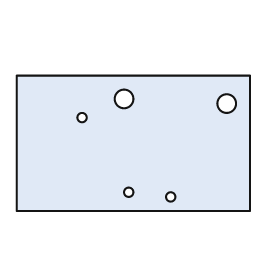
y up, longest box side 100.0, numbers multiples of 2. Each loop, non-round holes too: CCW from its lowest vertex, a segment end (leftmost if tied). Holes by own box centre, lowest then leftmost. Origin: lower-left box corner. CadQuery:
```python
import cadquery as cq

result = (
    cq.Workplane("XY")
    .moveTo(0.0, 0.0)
    .lineTo(100.0, 0.0)
    .lineTo(100.0, 58.0)
    .lineTo(0.0, 58.0)
    .close()
    .moveTo(66.0, 6.0)
    .circle(2.0)
    .moveTo(48.0, 8.0)
    .circle(2.0)
    .moveTo(28.0, 40.0)
    .circle(2.0)
    .moveTo(90.0, 46.0)
    .circle(4.0)
    .moveTo(46.0, 48.0)
    .circle(4.0)
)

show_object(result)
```